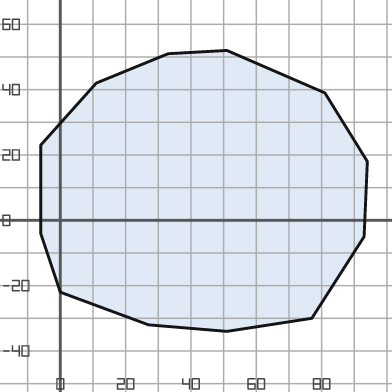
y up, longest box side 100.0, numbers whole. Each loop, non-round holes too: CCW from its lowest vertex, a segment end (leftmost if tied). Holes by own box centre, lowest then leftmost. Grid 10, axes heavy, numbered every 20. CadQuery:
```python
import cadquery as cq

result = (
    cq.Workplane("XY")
    .moveTo(51.0, -34.0)
    .lineTo(77.0, -30.0)
    .lineTo(93.0, -5.0)
    .lineTo(94.0, 18.0)
    .lineTo(81.0, 39.0)
    .lineTo(51.0, 52.0)
    .lineTo(33.0, 51.0)
    .lineTo(11.0, 42.0)
    .lineTo(-6.0, 23.0)
    .lineTo(-6.0, -4.0)
    .lineTo(0.0, -22.0)
    .lineTo(27.0, -32.0)
    .close()
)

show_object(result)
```